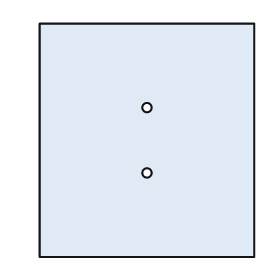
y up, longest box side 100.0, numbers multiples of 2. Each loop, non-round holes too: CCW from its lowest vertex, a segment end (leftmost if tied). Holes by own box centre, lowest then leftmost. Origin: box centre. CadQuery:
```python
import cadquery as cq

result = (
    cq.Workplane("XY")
    .moveTo(-46.0, -50.0)
    .lineTo(46.0, -50.0)
    .lineTo(46.0, 50.0)
    .lineTo(-46.0, 50.0)
    .close()
    .moveTo(0.0, -14.0)
    .circle(2.0)
    .moveTo(0.0, 14.0)
    .circle(2.0)
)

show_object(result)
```